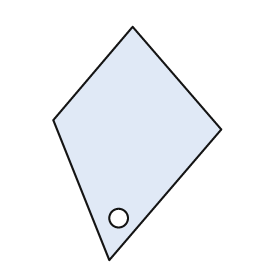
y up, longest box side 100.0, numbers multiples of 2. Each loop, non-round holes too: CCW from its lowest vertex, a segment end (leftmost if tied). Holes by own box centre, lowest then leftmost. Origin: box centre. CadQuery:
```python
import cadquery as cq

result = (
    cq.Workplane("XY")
    .moveTo(-12.0, -50.0)
    .lineTo(36.0, 6.0)
    .lineTo(-2.0, 50.0)
    .lineTo(-36.0, 10.0)
    .close()
    .moveTo(-8.0, -32.0)
    .circle(4.0)
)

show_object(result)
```